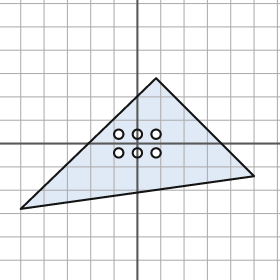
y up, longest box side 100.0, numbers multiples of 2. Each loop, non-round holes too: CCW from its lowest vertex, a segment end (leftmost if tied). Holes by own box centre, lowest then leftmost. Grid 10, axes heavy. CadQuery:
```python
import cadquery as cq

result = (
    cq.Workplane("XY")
    .moveTo(-50.0, -28.0)
    .lineTo(50.0, -14.0)
    .lineTo(8.0, 28.0)
    .close()
    .moveTo(-8.0, -4.0)
    .circle(2.0)
    .moveTo(0.0, -4.0)
    .circle(2.0)
    .moveTo(8.0, -4.0)
    .circle(2.0)
    .moveTo(-8.0, 4.0)
    .circle(2.0)
    .moveTo(0.0, 4.0)
    .circle(2.0)
    .moveTo(8.0, 4.0)
    .circle(2.0)
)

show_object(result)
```